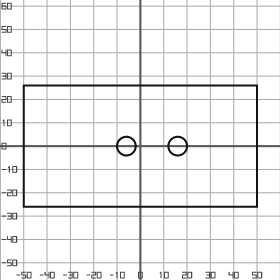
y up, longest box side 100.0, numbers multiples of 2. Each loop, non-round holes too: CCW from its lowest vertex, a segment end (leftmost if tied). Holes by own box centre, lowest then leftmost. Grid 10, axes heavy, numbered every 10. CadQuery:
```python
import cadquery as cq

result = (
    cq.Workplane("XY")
    .moveTo(-50.0, -26.0)
    .lineTo(50.0, -26.0)
    .lineTo(50.0, 26.0)
    .lineTo(-50.0, 26.0)
    .close()
    .moveTo(-6.0, 0.0)
    .circle(4.0)
    .moveTo(16.0, 0.0)
    .circle(4.0)
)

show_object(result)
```